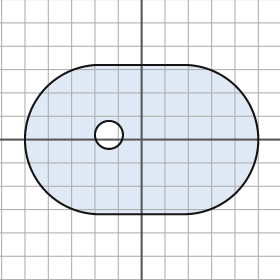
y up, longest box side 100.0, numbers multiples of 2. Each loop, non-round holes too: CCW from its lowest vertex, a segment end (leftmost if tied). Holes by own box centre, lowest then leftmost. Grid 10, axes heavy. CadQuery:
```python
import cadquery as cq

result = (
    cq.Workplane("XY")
    .moveTo(-18.0, -32.0)
    .lineTo(18.0, -32.0)
    .threePointArc((50.0, 0.0), (18.0, 32.0))
    .lineTo(-18.0, 32.0)
    .threePointArc((-50.0, 0.0), (-18.0, -32.0))
    .close()
    .moveTo(-14.0, 2.0)
    .circle(6.0)
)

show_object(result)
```